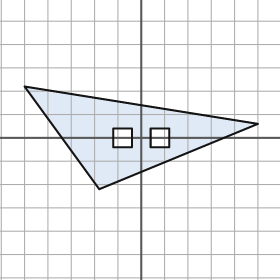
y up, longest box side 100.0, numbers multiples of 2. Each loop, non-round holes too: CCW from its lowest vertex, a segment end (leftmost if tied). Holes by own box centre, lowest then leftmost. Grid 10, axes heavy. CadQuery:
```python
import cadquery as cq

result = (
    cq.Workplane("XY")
    .moveTo(-18.0, -22.0)
    .lineTo(50.0, 6.0)
    .lineTo(-50.0, 22.0)
    .close()
    .moveTo(-12.0, -4.0)
    .lineTo(-4.0, -4.0)
    .lineTo(-4.0, 4.0)
    .lineTo(-12.0, 4.0)
    .close()
    .moveTo(4.0, -4.0)
    .lineTo(12.0, -4.0)
    .lineTo(12.0, 4.0)
    .lineTo(4.0, 4.0)
    .close()
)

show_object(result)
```